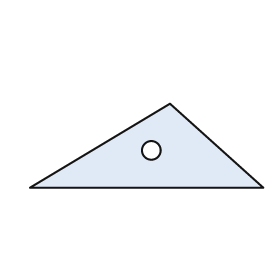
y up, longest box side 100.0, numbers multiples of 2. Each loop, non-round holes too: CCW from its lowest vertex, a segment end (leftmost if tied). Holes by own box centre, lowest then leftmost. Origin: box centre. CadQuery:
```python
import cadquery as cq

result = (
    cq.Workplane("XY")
    .moveTo(-50.0, -18.0)
    .lineTo(50.0, -18.0)
    .lineTo(10.0, 18.0)
    .close()
    .moveTo(2.0, -2.0)
    .circle(4.0)
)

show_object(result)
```